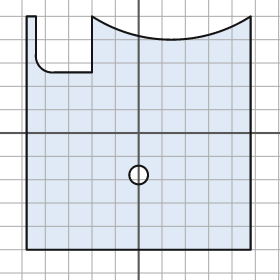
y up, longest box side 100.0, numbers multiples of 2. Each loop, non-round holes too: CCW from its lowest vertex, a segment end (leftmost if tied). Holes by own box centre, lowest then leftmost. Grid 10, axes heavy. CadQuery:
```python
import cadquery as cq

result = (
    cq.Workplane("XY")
    .moveTo(-48.0, -50.0)
    .lineTo(48.0, -50.0)
    .lineTo(48.0, 50.0)
    .threePointArc((14.0, 40.0), (-20.0, 50.0))
    .lineTo(-20.0, 26.0)
    .lineTo(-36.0, 26.0)
    .threePointArc((-42.0, 28.0), (-44.0, 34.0))
    .lineTo(-44.0, 50.0)
    .lineTo(-48.0, 50.0)
    .close()
    .moveTo(0.0, -18.0)
    .circle(4.0)
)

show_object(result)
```